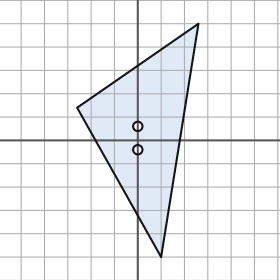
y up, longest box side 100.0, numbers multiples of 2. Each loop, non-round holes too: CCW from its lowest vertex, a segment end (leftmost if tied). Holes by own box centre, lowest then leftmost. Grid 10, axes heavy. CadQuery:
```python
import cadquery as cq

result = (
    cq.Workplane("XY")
    .moveTo(10.0, -50.0)
    .lineTo(26.0, 50.0)
    .lineTo(-26.0, 14.0)
    .close()
    .moveTo(0.0, -4.0)
    .circle(2.0)
    .moveTo(0.0, 6.0)
    .circle(2.0)
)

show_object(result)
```